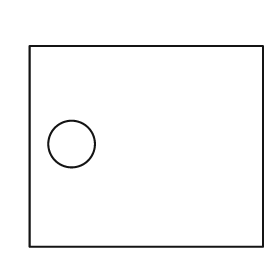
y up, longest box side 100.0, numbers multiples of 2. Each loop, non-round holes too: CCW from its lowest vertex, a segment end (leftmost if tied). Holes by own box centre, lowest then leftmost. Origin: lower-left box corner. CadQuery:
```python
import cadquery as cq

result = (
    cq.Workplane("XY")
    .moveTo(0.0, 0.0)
    .lineTo(100.0, 0.0)
    .lineTo(100.0, 86.0)
    .lineTo(0.0, 86.0)
    .close()
    .moveTo(18.0, 44.0)
    .circle(10.0)
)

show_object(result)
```